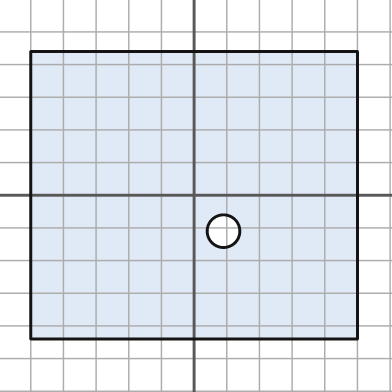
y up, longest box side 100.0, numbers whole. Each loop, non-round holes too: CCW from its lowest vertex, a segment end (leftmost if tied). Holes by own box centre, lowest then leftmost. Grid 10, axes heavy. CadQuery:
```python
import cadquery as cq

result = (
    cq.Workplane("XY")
    .moveTo(-50.0, -44.0)
    .lineTo(50.0, -44.0)
    .lineTo(50.0, 44.0)
    .lineTo(-50.0, 44.0)
    .close()
    .moveTo(9.0, -11.0)
    .circle(5.0)
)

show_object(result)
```